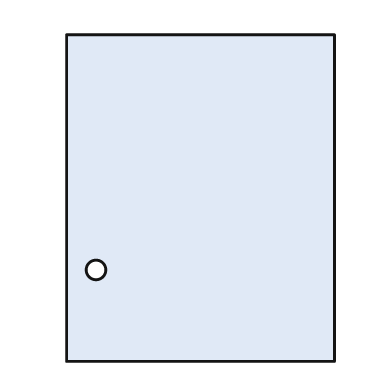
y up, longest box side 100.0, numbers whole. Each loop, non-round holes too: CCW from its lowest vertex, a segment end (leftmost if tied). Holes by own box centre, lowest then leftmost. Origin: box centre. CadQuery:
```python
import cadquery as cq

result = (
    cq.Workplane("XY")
    .moveTo(-41.0, -50.0)
    .lineTo(41.0, -50.0)
    .lineTo(41.0, 50.0)
    .lineTo(-41.0, 50.0)
    .close()
    .moveTo(-32.0, -22.0)
    .circle(3.0)
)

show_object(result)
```